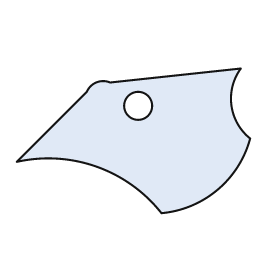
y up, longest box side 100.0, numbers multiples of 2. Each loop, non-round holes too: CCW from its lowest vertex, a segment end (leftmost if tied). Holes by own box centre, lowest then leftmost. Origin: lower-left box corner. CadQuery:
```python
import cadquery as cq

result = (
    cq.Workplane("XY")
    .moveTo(62.0, 0.0)
    .threePointArc((86.0, 10.0), (100.0, 32.0))
    .threePointArc((92.0, 46.0), (96.0, 62.0))
    .lineTo(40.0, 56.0)
    .threePointArc((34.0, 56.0), (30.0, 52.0))
    .lineTo(0.0, 22.0)
    .threePointArc((34.0, 20.0), (62.0, 0.0))
    .close()
    .moveTo(52.0, 46.0)
    .circle(6.0)
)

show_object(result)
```